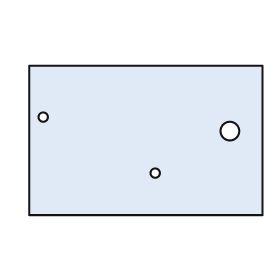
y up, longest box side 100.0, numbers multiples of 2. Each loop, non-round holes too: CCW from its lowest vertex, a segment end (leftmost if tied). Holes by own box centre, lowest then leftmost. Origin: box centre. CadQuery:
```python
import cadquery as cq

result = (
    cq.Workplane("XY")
    .moveTo(-50.0, -32.0)
    .lineTo(50.0, -32.0)
    .lineTo(50.0, 32.0)
    .lineTo(-50.0, 32.0)
    .close()
    .moveTo(4.0, -14.0)
    .circle(2.0)
    .moveTo(36.0, 4.0)
    .circle(4.0)
    .moveTo(-44.0, 10.0)
    .circle(2.0)
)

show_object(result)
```